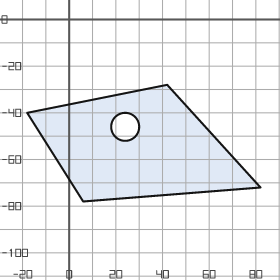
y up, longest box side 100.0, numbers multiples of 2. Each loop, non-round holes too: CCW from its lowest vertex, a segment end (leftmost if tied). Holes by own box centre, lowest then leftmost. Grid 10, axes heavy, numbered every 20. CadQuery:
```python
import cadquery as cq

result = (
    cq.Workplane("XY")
    .moveTo(6.0, -78.0)
    .lineTo(82.0, -72.0)
    .lineTo(42.0, -28.0)
    .lineTo(-18.0, -40.0)
    .close()
    .moveTo(24.0, -46.0)
    .circle(6.0)
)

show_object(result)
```